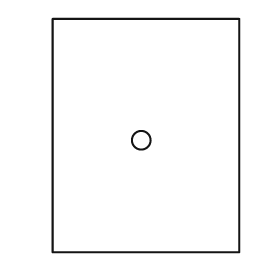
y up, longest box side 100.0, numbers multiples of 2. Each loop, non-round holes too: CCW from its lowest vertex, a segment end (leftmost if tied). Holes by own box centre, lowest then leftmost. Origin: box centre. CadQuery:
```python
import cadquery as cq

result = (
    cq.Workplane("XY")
    .moveTo(-40.0, -50.0)
    .lineTo(40.0, -50.0)
    .lineTo(40.0, 50.0)
    .lineTo(-40.0, 50.0)
    .close()
    .moveTo(-2.0, -2.0)
    .circle(4.0)
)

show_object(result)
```